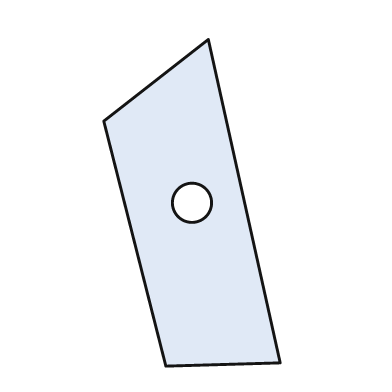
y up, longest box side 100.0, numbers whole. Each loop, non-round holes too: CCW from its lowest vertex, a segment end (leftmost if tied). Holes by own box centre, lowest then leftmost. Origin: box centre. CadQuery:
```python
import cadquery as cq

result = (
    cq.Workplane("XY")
    .moveTo(-8.0, -50.0)
    .lineTo(27.0, -49.0)
    .lineTo(5.0, 50.0)
    .lineTo(-27.0, 25.0)
    .close()
    .moveTo(0.0, 0.0)
    .circle(6.0)
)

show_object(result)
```